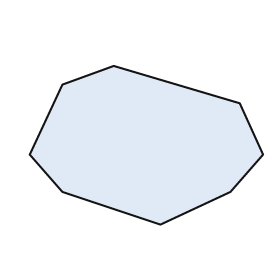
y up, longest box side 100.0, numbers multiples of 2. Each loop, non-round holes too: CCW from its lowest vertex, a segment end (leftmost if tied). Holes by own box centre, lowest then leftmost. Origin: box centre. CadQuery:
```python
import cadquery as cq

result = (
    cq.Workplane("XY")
    .moveTo(6.0, -34.0)
    .lineTo(36.0, -20.0)
    .lineTo(50.0, -4.0)
    .lineTo(40.0, 18.0)
    .lineTo(-14.0, 34.0)
    .lineTo(-36.0, 26.0)
    .lineTo(-50.0, -4.0)
    .lineTo(-36.0, -20.0)
    .close()
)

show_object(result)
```